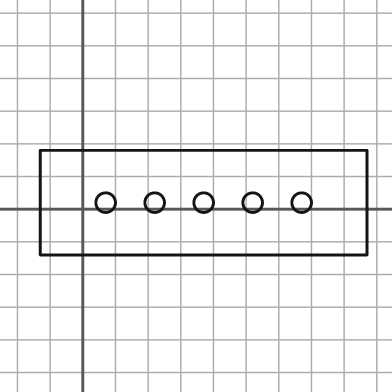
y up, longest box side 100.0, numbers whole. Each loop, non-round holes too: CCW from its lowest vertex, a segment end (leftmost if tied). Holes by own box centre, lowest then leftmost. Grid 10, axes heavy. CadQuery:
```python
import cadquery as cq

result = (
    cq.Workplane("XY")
    .moveTo(-13.0, -14.0)
    .lineTo(87.0, -14.0)
    .lineTo(87.0, 18.0)
    .lineTo(-13.0, 18.0)
    .close()
    .moveTo(7.0, 2.0)
    .circle(3.0)
    .moveTo(22.0, 2.0)
    .circle(3.0)
    .moveTo(37.0, 2.0)
    .circle(3.0)
    .moveTo(52.0, 2.0)
    .circle(3.0)
    .moveTo(67.0, 2.0)
    .circle(3.0)
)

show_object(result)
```